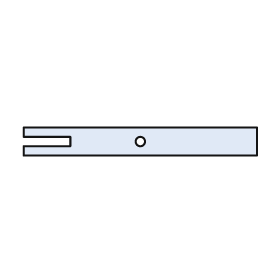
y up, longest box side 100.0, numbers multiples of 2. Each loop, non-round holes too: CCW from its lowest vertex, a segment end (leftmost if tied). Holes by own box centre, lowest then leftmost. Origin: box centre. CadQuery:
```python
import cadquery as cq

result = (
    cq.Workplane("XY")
    .moveTo(-50.0, -6.0)
    .lineTo(50.0, -6.0)
    .lineTo(50.0, 6.0)
    .lineTo(-50.0, 6.0)
    .lineTo(-50.0, 2.0)
    .lineTo(-30.0, 2.0)
    .lineTo(-30.0, -2.0)
    .lineTo(-50.0, -2.0)
    .close()
    .moveTo(0.0, 0.0)
    .circle(2.0)
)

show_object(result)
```